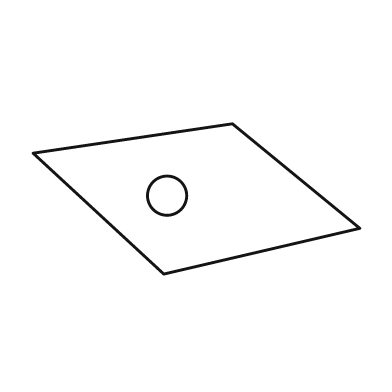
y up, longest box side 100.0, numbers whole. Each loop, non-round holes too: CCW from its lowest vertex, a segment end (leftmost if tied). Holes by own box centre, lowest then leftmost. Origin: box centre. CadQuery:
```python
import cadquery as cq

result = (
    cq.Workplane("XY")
    .moveTo(-10.0, -23.0)
    .lineTo(50.0, -9.0)
    .lineTo(11.0, 23.0)
    .lineTo(-50.0, 14.0)
    .close()
    .moveTo(-9.0, 1.0)
    .circle(6.0)
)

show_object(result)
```